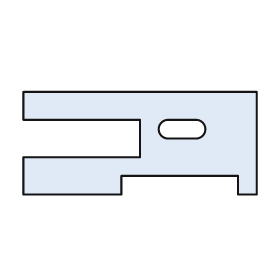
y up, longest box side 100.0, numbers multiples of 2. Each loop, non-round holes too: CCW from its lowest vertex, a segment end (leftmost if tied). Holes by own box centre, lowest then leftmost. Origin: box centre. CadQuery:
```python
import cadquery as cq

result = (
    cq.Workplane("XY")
    .moveTo(-50.0, -22.0)
    .lineTo(-8.0, -22.0)
    .lineTo(-8.0, -14.0)
    .lineTo(42.0, -14.0)
    .lineTo(42.0, -22.0)
    .lineTo(50.0, -22.0)
    .lineTo(50.0, 22.0)
    .lineTo(-50.0, 22.0)
    .lineTo(-50.0, 10.0)
    .lineTo(0.0, 10.0)
    .lineTo(0.0, -6.0)
    .lineTo(-50.0, -6.0)
    .close()
    .moveTo(12.0, 2.0)
    .lineTo(24.0, 2.0)
    .threePointArc((28.0, 6.0), (24.0, 10.0))
    .lineTo(12.0, 10.0)
    .threePointArc((8.0, 6.0), (12.0, 2.0))
    .close()
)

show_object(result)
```